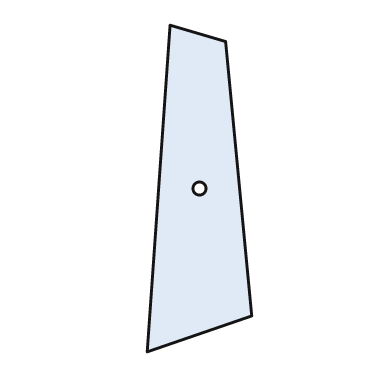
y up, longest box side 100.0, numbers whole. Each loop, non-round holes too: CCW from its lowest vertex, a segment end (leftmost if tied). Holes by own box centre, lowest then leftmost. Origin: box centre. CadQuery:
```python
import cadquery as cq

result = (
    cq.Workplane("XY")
    .moveTo(-16.0, -50.0)
    .lineTo(16.0, -39.0)
    .lineTo(8.0, 45.0)
    .lineTo(-9.0, 50.0)
    .close()
    .moveTo(0.0, 0.0)
    .circle(2.0)
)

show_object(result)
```